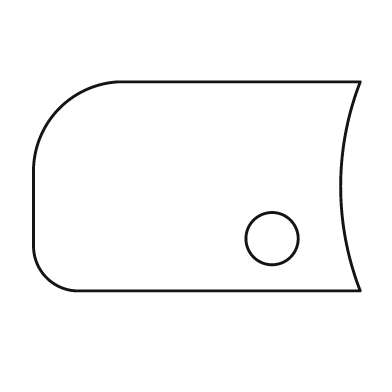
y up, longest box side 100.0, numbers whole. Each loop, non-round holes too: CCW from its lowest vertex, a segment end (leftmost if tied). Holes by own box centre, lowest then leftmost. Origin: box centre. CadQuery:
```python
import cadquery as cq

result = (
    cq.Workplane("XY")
    .moveTo(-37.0, -32.0)
    .lineTo(50.0, -32.0)
    .threePointArc((44.0, 0.0), (50.0, 32.0))
    .lineTo(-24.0, 32.0)
    .threePointArc((-42.0, 24.0), (-50.0, 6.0))
    .lineTo(-50.0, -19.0)
    .threePointArc((-46.0, -28.0), (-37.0, -32.0))
    .close()
    .moveTo(23.0, -16.0)
    .circle(8.0)
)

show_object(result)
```